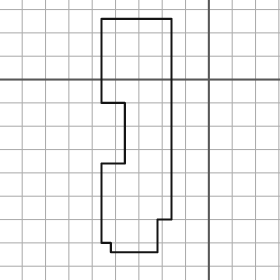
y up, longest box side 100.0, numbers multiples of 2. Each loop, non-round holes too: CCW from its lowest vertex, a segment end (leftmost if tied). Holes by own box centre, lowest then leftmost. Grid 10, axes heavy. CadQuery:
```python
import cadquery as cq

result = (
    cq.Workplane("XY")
    .moveTo(-42.0, -74.0)
    .lineTo(-22.0, -74.0)
    .lineTo(-22.0, -60.0)
    .lineTo(-16.0, -60.0)
    .lineTo(-16.0, 26.0)
    .lineTo(-46.0, 26.0)
    .lineTo(-46.0, -10.0)
    .lineTo(-36.0, -10.0)
    .lineTo(-36.0, -36.0)
    .lineTo(-46.0, -36.0)
    .lineTo(-46.0, -70.0)
    .lineTo(-42.0, -70.0)
    .close()
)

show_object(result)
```